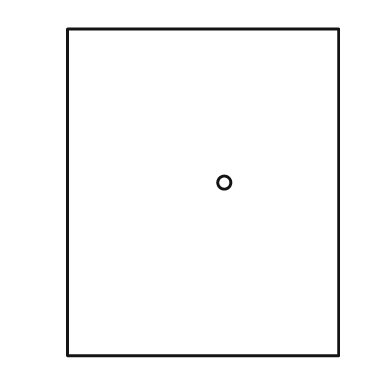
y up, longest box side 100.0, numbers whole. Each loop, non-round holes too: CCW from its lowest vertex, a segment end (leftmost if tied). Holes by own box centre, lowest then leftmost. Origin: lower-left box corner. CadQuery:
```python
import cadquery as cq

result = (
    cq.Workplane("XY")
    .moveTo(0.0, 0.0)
    .lineTo(83.0, 0.0)
    .lineTo(83.0, 100.0)
    .lineTo(0.0, 100.0)
    .close()
    .moveTo(48.0, 53.0)
    .circle(2.0)
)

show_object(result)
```